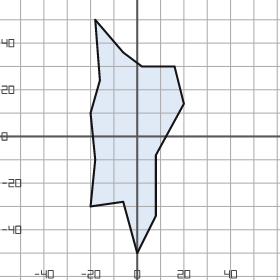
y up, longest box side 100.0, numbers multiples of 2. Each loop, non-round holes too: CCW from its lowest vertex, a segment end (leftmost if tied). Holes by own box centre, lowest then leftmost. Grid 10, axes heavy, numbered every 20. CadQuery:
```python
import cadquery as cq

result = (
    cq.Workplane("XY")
    .moveTo(0.0, -50.0)
    .lineTo(8.0, -34.0)
    .lineTo(8.0, -8.0)
    .lineTo(20.0, 14.0)
    .lineTo(16.0, 30.0)
    .lineTo(2.0, 30.0)
    .lineTo(-6.0, 36.0)
    .lineTo(-18.0, 50.0)
    .lineTo(-16.0, 24.0)
    .lineTo(-20.0, 10.0)
    .lineTo(-18.0, -10.0)
    .lineTo(-20.0, -30.0)
    .lineTo(-6.0, -28.0)
    .close()
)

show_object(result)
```